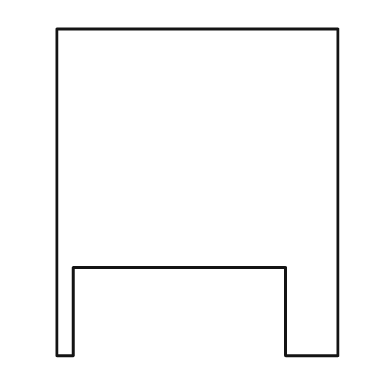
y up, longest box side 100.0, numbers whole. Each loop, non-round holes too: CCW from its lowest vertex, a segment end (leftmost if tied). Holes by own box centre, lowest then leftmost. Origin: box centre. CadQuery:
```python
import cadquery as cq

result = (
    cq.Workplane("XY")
    .moveTo(-43.0, -50.0)
    .lineTo(-38.0, -50.0)
    .lineTo(-38.0, -23.0)
    .lineTo(27.0, -23.0)
    .lineTo(27.0, -50.0)
    .lineTo(43.0, -50.0)
    .lineTo(43.0, 50.0)
    .lineTo(-43.0, 50.0)
    .close()
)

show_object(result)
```